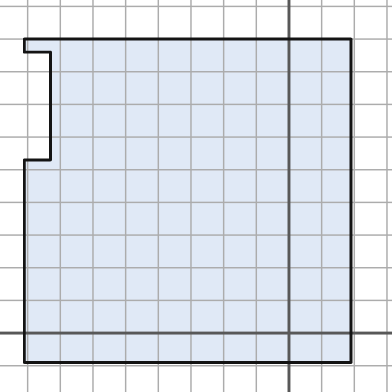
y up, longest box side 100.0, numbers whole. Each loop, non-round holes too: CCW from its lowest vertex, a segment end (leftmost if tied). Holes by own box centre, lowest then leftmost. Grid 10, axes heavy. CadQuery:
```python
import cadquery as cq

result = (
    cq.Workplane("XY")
    .moveTo(-81.0, -9.0)
    .lineTo(19.0, -9.0)
    .lineTo(19.0, 90.0)
    .lineTo(-81.0, 90.0)
    .lineTo(-81.0, 86.0)
    .lineTo(-73.0, 86.0)
    .lineTo(-73.0, 53.0)
    .lineTo(-81.0, 53.0)
    .close()
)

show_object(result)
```